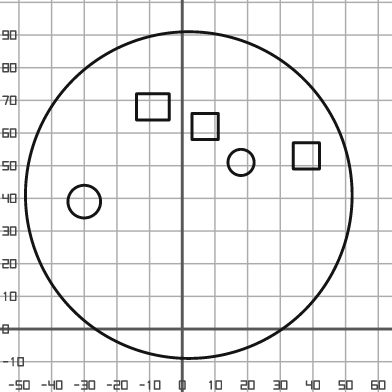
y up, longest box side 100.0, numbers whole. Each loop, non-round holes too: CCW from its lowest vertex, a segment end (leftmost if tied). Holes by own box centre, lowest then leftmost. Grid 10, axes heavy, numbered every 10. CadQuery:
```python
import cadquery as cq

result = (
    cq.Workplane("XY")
    .moveTo(2.0, 41.0)
    .circle(50.0)
    .moveTo(-30.0, 39.0)
    .circle(5.0)
    .moveTo(18.0, 51.0)
    .circle(4.0)
    .moveTo(34.0, 49.0)
    .lineTo(42.0, 49.0)
    .lineTo(42.0, 57.0)
    .lineTo(34.0, 57.0)
    .close()
    .moveTo(3.0, 58.0)
    .lineTo(11.0, 58.0)
    .lineTo(11.0, 66.0)
    .lineTo(3.0, 66.0)
    .close()
    .moveTo(-14.0, 64.0)
    .lineTo(-4.0, 64.0)
    .lineTo(-4.0, 72.0)
    .lineTo(-14.0, 72.0)
    .close()
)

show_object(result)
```